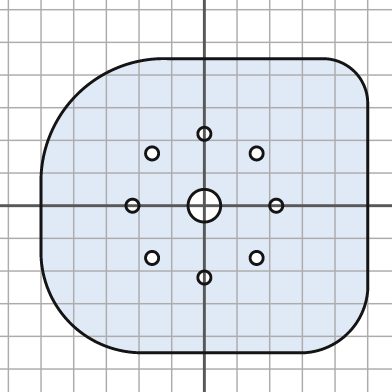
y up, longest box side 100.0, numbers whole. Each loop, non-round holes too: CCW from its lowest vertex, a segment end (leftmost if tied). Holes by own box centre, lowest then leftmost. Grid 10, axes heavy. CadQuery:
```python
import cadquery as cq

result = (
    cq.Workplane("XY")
    .moveTo(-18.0, -45.0)
    .lineTo(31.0, -45.0)
    .threePointArc((44.0, -39.0), (50.0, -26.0))
    .lineTo(50.0, 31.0)
    .threePointArc((46.0, 41.0), (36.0, 45.0))
    .lineTo(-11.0, 45.0)
    .threePointArc((-39.0, 34.0), (-50.0, 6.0))
    .lineTo(-50.0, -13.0)
    .threePointArc((-41.0, -36.0), (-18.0, -45.0))
    .close()
    .moveTo(0.0, -22.0)
    .circle(2.0)
    .moveTo(-16.0, -16.0)
    .circle(2.0)
    .moveTo(16.0, -16.0)
    .circle(2.0)
    .moveTo(-22.0, 0.0)
    .circle(2.0)
    .moveTo(0.0, 0.0)
    .circle(5.0)
    .moveTo(22.0, 0.0)
    .circle(2.0)
    .moveTo(-16.0, 16.0)
    .circle(2.0)
    .moveTo(16.0, 16.0)
    .circle(2.0)
    .moveTo(0.0, 22.0)
    .circle(2.0)
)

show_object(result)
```